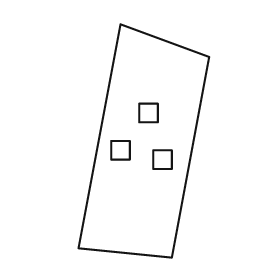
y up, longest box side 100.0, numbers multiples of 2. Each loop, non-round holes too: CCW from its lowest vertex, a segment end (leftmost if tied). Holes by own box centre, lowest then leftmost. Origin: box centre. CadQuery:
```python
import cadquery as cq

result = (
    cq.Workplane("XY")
    .moveTo(12.0, -50.0)
    .lineTo(28.0, 36.0)
    .lineTo(-10.0, 50.0)
    .lineTo(-28.0, -46.0)
    .close()
    .moveTo(4.0, -12.0)
    .lineTo(12.0, -12.0)
    .lineTo(12.0, -4.0)
    .lineTo(4.0, -4.0)
    .close()
    .moveTo(-14.0, -8.0)
    .lineTo(-6.0, -8.0)
    .lineTo(-6.0, 0.0)
    .lineTo(-14.0, 0.0)
    .close()
    .moveTo(-2.0, 8.0)
    .lineTo(6.0, 8.0)
    .lineTo(6.0, 16.0)
    .lineTo(-2.0, 16.0)
    .close()
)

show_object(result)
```